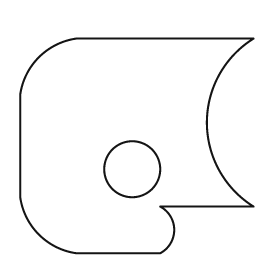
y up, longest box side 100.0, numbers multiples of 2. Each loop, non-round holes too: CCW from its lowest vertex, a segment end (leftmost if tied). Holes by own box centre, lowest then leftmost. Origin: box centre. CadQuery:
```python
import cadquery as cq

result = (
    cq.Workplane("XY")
    .moveTo(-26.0, -46.0)
    .lineTo(10.0, -46.0)
    .threePointArc((16.0, -36.0), (10.0, -26.0))
    .lineTo(50.0, -26.0)
    .threePointArc((30.0, 10.0), (50.0, 46.0))
    .lineTo(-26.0, 46.0)
    .threePointArc((-42.0, 38.0), (-50.0, 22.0))
    .lineTo(-50.0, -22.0)
    .threePointArc((-42.0, -38.0), (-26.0, -46.0))
    .close()
    .moveTo(-2.0, -10.0)
    .circle(12.0)
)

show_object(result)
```